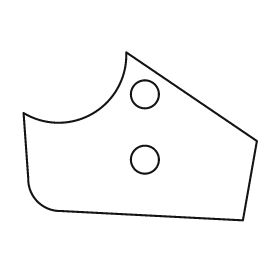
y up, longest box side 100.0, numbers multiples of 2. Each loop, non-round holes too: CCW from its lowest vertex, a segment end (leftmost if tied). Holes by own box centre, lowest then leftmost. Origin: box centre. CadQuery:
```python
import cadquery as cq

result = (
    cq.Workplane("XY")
    .moveTo(44.0, -36.0)
    .lineTo(50.0, -2.0)
    .lineTo(-6.0, 36.0)
    .threePointArc((-20.0, 10.0), (-50.0, 10.0))
    .lineTo(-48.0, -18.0)
    .threePointArc((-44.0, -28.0), (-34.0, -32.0))
    .close()
    .moveTo(2.0, -10.0)
    .circle(6.0)
    .moveTo(2.0, 18.0)
    .circle(6.0)
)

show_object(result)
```